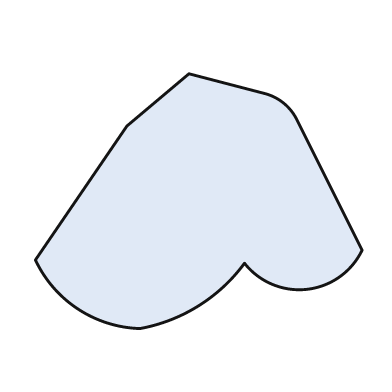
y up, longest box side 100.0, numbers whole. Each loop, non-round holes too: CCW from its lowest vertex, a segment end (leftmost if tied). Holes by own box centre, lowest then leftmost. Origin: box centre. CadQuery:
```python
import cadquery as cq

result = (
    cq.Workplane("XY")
    .moveTo(-18.0, -39.0)
    .threePointArc((0.0, -32.0), (14.0, -19.0))
    .threePointArc((33.0, -27.0), (50.0, -15.0))
    .lineTo(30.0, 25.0)
    .threePointArc((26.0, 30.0), (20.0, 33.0))
    .lineTo(-3.0, 39.0)
    .lineTo(-22.0, 23.0)
    .lineTo(-50.0, -18.0)
    .threePointArc((-37.0, -33.0), (-18.0, -39.0))
    .close()
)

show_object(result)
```